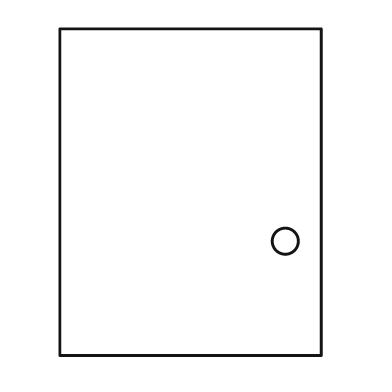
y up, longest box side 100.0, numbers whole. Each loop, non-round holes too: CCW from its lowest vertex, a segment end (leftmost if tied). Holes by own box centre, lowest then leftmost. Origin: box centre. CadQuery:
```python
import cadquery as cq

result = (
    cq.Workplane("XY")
    .moveTo(-40.0, -50.0)
    .lineTo(40.0, -50.0)
    .lineTo(40.0, 50.0)
    .lineTo(-40.0, 50.0)
    .close()
    .moveTo(29.0, -15.0)
    .circle(4.0)
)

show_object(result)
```